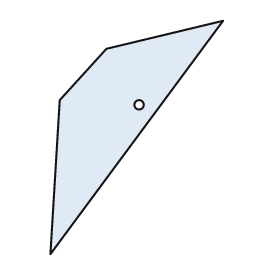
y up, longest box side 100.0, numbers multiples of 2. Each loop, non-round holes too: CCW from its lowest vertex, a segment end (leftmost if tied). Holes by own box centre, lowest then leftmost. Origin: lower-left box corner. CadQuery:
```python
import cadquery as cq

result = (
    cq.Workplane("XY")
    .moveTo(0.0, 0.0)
    .lineTo(74.0, 100.0)
    .lineTo(24.0, 88.0)
    .lineTo(4.0, 66.0)
    .close()
    .moveTo(38.0, 64.0)
    .circle(2.0)
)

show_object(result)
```